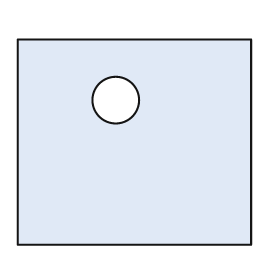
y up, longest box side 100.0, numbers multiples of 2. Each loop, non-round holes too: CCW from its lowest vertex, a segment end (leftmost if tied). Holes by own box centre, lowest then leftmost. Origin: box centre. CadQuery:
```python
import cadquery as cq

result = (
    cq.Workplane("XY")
    .moveTo(-50.0, -44.0)
    .lineTo(50.0, -44.0)
    .lineTo(50.0, 44.0)
    .lineTo(-50.0, 44.0)
    .close()
    .moveTo(-8.0, 18.0)
    .circle(10.0)
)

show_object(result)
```